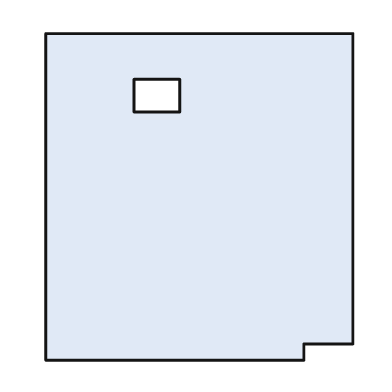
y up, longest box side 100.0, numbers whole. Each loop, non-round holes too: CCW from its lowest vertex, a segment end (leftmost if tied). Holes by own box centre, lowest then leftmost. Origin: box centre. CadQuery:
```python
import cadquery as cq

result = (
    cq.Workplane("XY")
    .moveTo(-47.0, -50.0)
    .lineTo(32.0, -50.0)
    .lineTo(32.0, -45.0)
    .lineTo(47.0, -45.0)
    .lineTo(47.0, 50.0)
    .lineTo(-47.0, 50.0)
    .close()
    .moveTo(-20.0, 26.0)
    .lineTo(-6.0, 26.0)
    .lineTo(-6.0, 36.0)
    .lineTo(-20.0, 36.0)
    .close()
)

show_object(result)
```